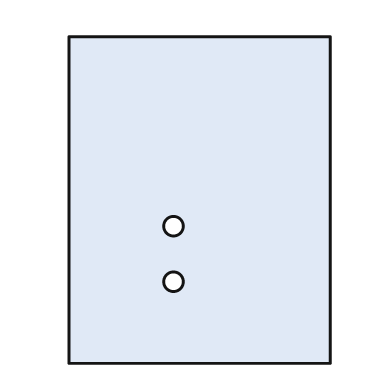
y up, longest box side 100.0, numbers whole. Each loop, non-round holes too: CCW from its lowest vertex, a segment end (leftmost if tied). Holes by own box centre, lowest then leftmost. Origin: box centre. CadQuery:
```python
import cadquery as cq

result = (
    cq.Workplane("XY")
    .moveTo(-40.0, -50.0)
    .lineTo(40.0, -50.0)
    .lineTo(40.0, 50.0)
    .lineTo(-40.0, 50.0)
    .close()
    .moveTo(-8.0, -25.0)
    .circle(3.0)
    .moveTo(-8.0, -8.0)
    .circle(3.0)
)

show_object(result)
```